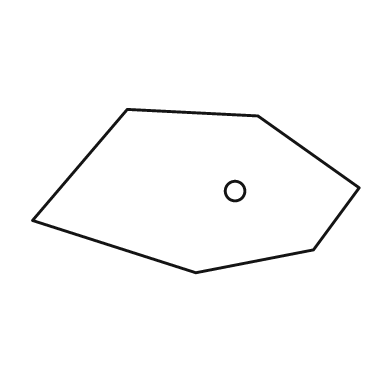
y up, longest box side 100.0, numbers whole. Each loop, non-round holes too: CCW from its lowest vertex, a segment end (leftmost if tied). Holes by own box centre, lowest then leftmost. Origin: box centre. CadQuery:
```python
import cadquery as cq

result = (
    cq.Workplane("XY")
    .moveTo(0.0, -25.0)
    .lineTo(36.0, -18.0)
    .lineTo(50.0, 1.0)
    .lineTo(19.0, 23.0)
    .lineTo(-21.0, 25.0)
    .lineTo(-50.0, -9.0)
    .close()
    .moveTo(12.0, 0.0)
    .circle(3.0)
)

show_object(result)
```